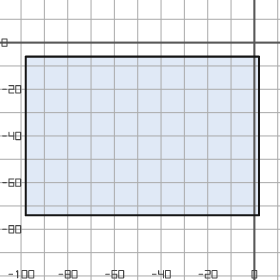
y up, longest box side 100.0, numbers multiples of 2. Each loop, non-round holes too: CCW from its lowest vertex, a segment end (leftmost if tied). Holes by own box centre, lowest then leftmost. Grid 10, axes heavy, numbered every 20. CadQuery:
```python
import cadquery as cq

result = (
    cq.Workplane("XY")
    .moveTo(-98.0, -74.0)
    .lineTo(2.0, -74.0)
    .lineTo(2.0, -6.0)
    .lineTo(-98.0, -6.0)
    .close()
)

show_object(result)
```